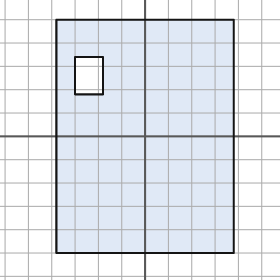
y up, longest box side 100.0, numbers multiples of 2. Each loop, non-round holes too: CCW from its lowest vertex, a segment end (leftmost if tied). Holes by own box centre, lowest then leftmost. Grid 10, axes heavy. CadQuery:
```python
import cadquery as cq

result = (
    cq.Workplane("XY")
    .moveTo(-38.0, -50.0)
    .lineTo(38.0, -50.0)
    .lineTo(38.0, 50.0)
    .lineTo(-38.0, 50.0)
    .close()
    .moveTo(-30.0, 18.0)
    .lineTo(-18.0, 18.0)
    .lineTo(-18.0, 34.0)
    .lineTo(-30.0, 34.0)
    .close()
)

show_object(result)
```